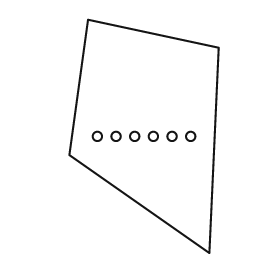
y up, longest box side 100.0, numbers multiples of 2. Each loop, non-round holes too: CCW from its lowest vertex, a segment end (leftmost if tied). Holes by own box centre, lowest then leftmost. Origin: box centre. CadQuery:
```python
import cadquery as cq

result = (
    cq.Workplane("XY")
    .moveTo(28.0, -50.0)
    .lineTo(32.0, 38.0)
    .lineTo(-24.0, 50.0)
    .lineTo(-32.0, -8.0)
    .close()
    .moveTo(-20.0, 0.0)
    .circle(2.0)
    .moveTo(-12.0, 0.0)
    .circle(2.0)
    .moveTo(-4.0, 0.0)
    .circle(2.0)
    .moveTo(4.0, 0.0)
    .circle(2.0)
    .moveTo(12.0, 0.0)
    .circle(2.0)
    .moveTo(20.0, 0.0)
    .circle(2.0)
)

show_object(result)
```